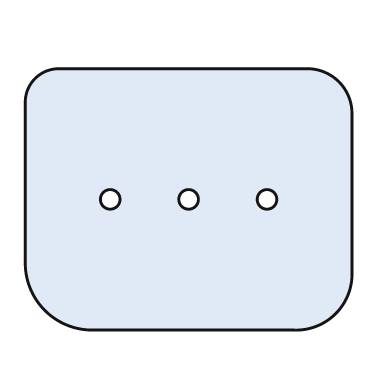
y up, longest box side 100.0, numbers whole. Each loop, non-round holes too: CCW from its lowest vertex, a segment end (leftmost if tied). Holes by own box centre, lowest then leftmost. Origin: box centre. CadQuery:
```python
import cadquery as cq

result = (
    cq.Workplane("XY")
    .moveTo(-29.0, -40.0)
    .lineTo(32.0, -40.0)
    .threePointArc((45.0, -35.0), (50.0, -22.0))
    .lineTo(50.0, 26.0)
    .threePointArc((46.0, 36.0), (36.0, 40.0))
    .lineTo(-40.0, 40.0)
    .threePointArc((-47.0, 37.0), (-50.0, 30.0))
    .lineTo(-50.0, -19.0)
    .threePointArc((-44.0, -34.0), (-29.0, -40.0))
    .close()
    .moveTo(-24.0, 0.0)
    .circle(3.0)
    .moveTo(0.0, 0.0)
    .circle(3.0)
    .moveTo(24.0, 0.0)
    .circle(3.0)
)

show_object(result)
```